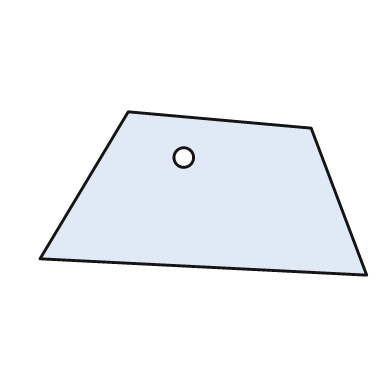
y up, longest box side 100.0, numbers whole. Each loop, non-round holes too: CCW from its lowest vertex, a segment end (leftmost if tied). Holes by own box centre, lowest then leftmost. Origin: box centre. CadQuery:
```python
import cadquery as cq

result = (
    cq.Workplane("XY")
    .moveTo(50.0, -25.0)
    .lineTo(33.0, 20.0)
    .lineTo(-23.0, 25.0)
    .lineTo(-50.0, -20.0)
    .close()
    .moveTo(-6.0, 11.0)
    .circle(3.0)
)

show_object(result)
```